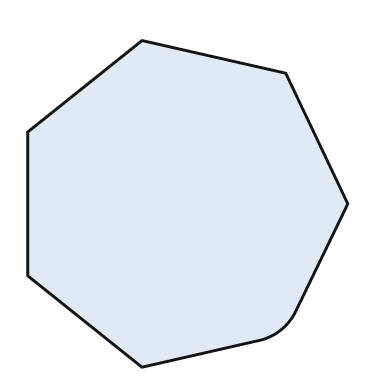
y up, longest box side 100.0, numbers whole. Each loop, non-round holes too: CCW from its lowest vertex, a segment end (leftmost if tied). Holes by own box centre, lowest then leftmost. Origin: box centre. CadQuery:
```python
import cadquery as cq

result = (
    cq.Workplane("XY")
    .moveTo(-14.0, -50.0)
    .lineTo(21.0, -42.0)
    .threePointArc((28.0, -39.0), (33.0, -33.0))
    .lineTo(49.0, 0.0)
    .lineTo(30.0, 40.0)
    .lineTo(-14.0, 50.0)
    .lineTo(-49.0, 22.0)
    .lineTo(-49.0, -22.0)
    .close()
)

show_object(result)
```